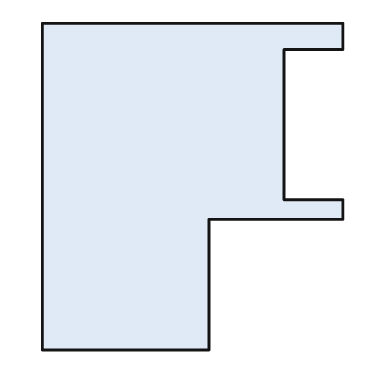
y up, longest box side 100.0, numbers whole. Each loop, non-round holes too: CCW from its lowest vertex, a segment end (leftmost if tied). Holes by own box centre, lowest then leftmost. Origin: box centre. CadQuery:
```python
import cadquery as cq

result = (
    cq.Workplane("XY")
    .moveTo(-46.0, -50.0)
    .lineTo(5.0, -50.0)
    .lineTo(5.0, -10.0)
    .lineTo(46.0, -10.0)
    .lineTo(46.0, -4.0)
    .lineTo(28.0, -4.0)
    .lineTo(28.0, 42.0)
    .lineTo(46.0, 42.0)
    .lineTo(46.0, 50.0)
    .lineTo(-46.0, 50.0)
    .close()
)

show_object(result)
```